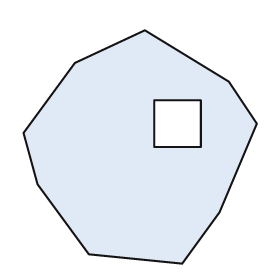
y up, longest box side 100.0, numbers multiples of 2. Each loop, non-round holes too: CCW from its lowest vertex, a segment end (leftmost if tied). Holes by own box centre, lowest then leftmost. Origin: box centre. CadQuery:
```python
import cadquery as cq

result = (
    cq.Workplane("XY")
    .moveTo(18.0, -50.0)
    .lineTo(34.0, -28.0)
    .lineTo(50.0, 10.0)
    .lineTo(38.0, 28.0)
    .lineTo(2.0, 50.0)
    .lineTo(-28.0, 36.0)
    .lineTo(-50.0, 6.0)
    .lineTo(-44.0, -16.0)
    .lineTo(-22.0, -46.0)
    .close()
    .moveTo(6.0, 0.0)
    .lineTo(26.0, 0.0)
    .lineTo(26.0, 20.0)
    .lineTo(6.0, 20.0)
    .close()
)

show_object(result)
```